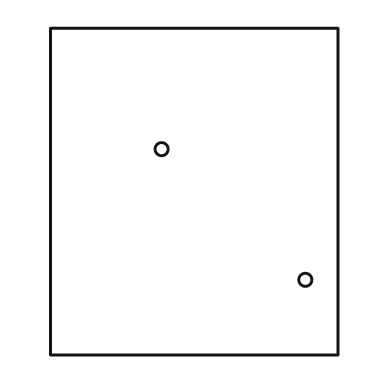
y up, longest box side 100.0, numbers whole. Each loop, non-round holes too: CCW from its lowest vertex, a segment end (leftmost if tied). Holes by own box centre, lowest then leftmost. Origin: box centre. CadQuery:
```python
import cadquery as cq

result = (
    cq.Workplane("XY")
    .moveTo(-44.0, -50.0)
    .lineTo(44.0, -50.0)
    .lineTo(44.0, 50.0)
    .lineTo(-44.0, 50.0)
    .close()
    .moveTo(34.0, -27.0)
    .circle(2.0)
    .moveTo(-10.0, 13.0)
    .circle(2.0)
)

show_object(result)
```